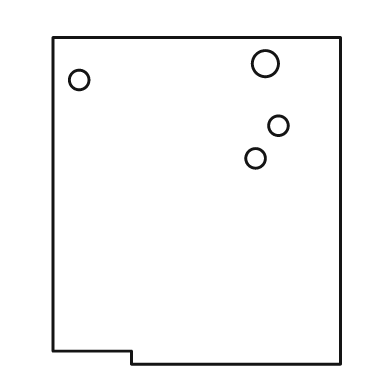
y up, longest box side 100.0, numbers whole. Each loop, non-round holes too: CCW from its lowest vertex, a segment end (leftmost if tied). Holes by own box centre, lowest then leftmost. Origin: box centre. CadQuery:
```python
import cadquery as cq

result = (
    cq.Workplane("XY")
    .moveTo(-20.0, -50.0)
    .lineTo(44.0, -50.0)
    .lineTo(44.0, 50.0)
    .lineTo(-44.0, 50.0)
    .lineTo(-44.0, -46.0)
    .lineTo(-20.0, -46.0)
    .close()
    .moveTo(18.0, 13.0)
    .circle(3.0)
    .moveTo(25.0, 23.0)
    .circle(3.0)
    .moveTo(-36.0, 37.0)
    .circle(3.0)
    .moveTo(21.0, 42.0)
    .circle(4.0)
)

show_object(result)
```